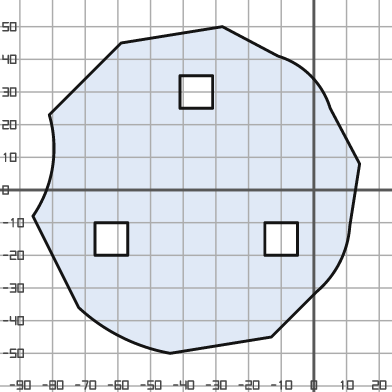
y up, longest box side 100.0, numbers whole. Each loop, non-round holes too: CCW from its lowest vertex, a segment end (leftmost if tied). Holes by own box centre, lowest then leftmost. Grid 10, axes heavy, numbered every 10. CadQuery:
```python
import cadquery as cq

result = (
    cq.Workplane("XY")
    .moveTo(-44.0, -50.0)
    .lineTo(-13.0, -45.0)
    .lineTo(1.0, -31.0)
    .threePointArc((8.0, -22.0), (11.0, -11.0))
    .lineTo(14.0, 8.0)
    .lineTo(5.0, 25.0)
    .threePointArc((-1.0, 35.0), (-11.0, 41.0))
    .lineTo(-28.0, 50.0)
    .lineTo(-59.0, 45.0)
    .lineTo(-81.0, 23.0)
    .threePointArc((-80.0, 7.0), (-86.0, -8.0))
    .lineTo(-72.0, -36.0)
    .threePointArc((-59.0, -45.0), (-44.0, -50.0))
    .close()
    .moveTo(-67.0, -20.0)
    .lineTo(-57.0, -20.0)
    .lineTo(-57.0, -10.0)
    .lineTo(-67.0, -10.0)
    .close()
    .moveTo(-15.0, -20.0)
    .lineTo(-5.0, -20.0)
    .lineTo(-5.0, -10.0)
    .lineTo(-15.0, -10.0)
    .close()
    .moveTo(-41.0, 25.0)
    .lineTo(-31.0, 25.0)
    .lineTo(-31.0, 35.0)
    .lineTo(-41.0, 35.0)
    .close()
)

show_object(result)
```